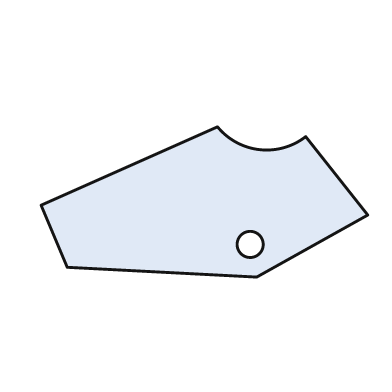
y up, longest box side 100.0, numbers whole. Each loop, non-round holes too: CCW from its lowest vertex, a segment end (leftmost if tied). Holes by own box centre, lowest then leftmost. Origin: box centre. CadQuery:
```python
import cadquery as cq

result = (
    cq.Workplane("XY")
    .moveTo(16.0, -23.0)
    .lineTo(50.0, -4.0)
    .lineTo(31.0, 20.0)
    .threePointArc((17.0, 16.0), (4.0, 23.0))
    .lineTo(-50.0, -1.0)
    .lineTo(-42.0, -20.0)
    .close()
    .moveTo(14.0, -13.0)
    .circle(4.0)
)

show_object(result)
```